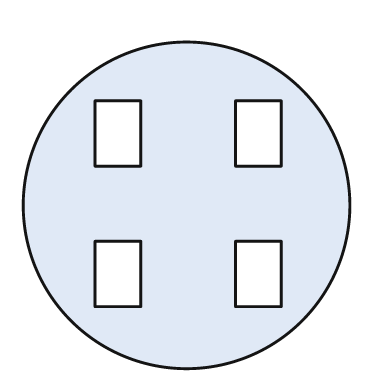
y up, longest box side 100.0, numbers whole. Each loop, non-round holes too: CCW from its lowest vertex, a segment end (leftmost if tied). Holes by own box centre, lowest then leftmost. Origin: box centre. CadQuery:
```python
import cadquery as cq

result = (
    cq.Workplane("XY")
    .moveTo(0.0, 0.0)
    .circle(50.0)
    .moveTo(-28.0, -31.0)
    .lineTo(-14.0, -31.0)
    .lineTo(-14.0, -11.0)
    .lineTo(-28.0, -11.0)
    .close()
    .moveTo(15.0, -31.0)
    .lineTo(29.0, -31.0)
    .lineTo(29.0, -11.0)
    .lineTo(15.0, -11.0)
    .close()
    .moveTo(-28.0, 12.0)
    .lineTo(-14.0, 12.0)
    .lineTo(-14.0, 32.0)
    .lineTo(-28.0, 32.0)
    .close()
    .moveTo(15.0, 12.0)
    .lineTo(29.0, 12.0)
    .lineTo(29.0, 32.0)
    .lineTo(15.0, 32.0)
    .close()
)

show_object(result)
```